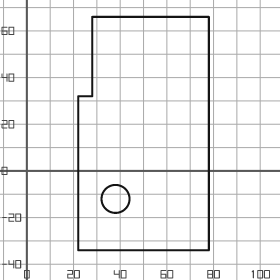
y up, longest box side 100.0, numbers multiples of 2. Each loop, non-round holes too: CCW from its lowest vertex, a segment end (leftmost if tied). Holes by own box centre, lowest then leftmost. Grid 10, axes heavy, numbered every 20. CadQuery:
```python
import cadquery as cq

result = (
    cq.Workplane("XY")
    .moveTo(22.0, -34.0)
    .lineTo(78.0, -34.0)
    .lineTo(78.0, 66.0)
    .lineTo(28.0, 66.0)
    .lineTo(28.0, 32.0)
    .lineTo(22.0, 32.0)
    .close()
    .moveTo(38.0, -12.0)
    .circle(6.0)
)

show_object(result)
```